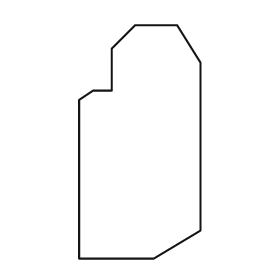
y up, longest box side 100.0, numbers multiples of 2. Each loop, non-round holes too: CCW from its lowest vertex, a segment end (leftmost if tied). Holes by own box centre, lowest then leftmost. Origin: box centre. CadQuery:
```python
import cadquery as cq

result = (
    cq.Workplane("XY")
    .moveTo(-26.0, -50.0)
    .lineTo(6.0, -50.0)
    .lineTo(26.0, -38.0)
    .lineTo(26.0, 34.0)
    .lineTo(16.0, 50.0)
    .lineTo(-2.0, 50.0)
    .lineTo(-12.0, 40.0)
    .lineTo(-12.0, 22.0)
    .lineTo(-20.0, 22.0)
    .lineTo(-26.0, 18.0)
    .close()
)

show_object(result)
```